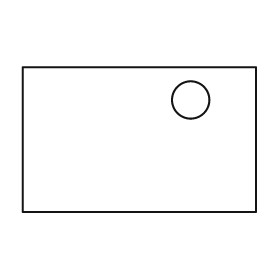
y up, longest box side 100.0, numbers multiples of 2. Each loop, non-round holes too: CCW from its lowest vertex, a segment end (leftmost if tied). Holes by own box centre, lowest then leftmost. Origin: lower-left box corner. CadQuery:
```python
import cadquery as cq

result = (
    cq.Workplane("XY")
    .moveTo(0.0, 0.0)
    .lineTo(100.0, 0.0)
    .lineTo(100.0, 62.0)
    .lineTo(0.0, 62.0)
    .close()
    .moveTo(72.0, 48.0)
    .circle(8.0)
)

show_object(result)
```